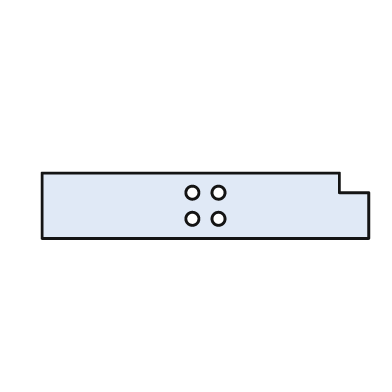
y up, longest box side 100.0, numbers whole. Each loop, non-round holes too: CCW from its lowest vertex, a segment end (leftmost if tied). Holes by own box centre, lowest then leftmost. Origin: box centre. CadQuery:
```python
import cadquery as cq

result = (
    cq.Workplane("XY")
    .moveTo(-50.0, -10.0)
    .lineTo(50.0, -10.0)
    .lineTo(50.0, 4.0)
    .lineTo(41.0, 4.0)
    .lineTo(41.0, 10.0)
    .lineTo(-50.0, 10.0)
    .close()
    .moveTo(-4.0, -4.0)
    .circle(2.0)
    .moveTo(4.0, -4.0)
    .circle(2.0)
    .moveTo(-4.0, 4.0)
    .circle(2.0)
    .moveTo(4.0, 4.0)
    .circle(2.0)
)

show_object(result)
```